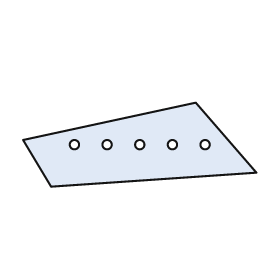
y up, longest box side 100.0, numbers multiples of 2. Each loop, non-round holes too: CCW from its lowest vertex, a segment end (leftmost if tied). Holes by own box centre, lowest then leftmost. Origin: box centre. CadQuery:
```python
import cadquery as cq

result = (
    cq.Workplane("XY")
    .moveTo(-38.0, -18.0)
    .lineTo(50.0, -12.0)
    .lineTo(24.0, 18.0)
    .lineTo(-50.0, 2.0)
    .close()
    .moveTo(-28.0, 0.0)
    .circle(2.0)
    .moveTo(-14.0, 0.0)
    .circle(2.0)
    .moveTo(0.0, 0.0)
    .circle(2.0)
    .moveTo(14.0, 0.0)
    .circle(2.0)
    .moveTo(28.0, 0.0)
    .circle(2.0)
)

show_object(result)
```